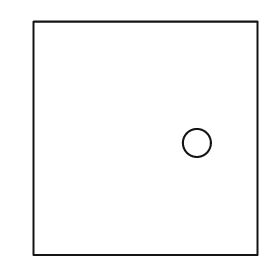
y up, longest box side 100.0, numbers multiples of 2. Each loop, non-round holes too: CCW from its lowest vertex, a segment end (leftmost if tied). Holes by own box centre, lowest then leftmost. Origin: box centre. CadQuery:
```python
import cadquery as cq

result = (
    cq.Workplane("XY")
    .moveTo(-48.0, -50.0)
    .lineTo(48.0, -50.0)
    .lineTo(48.0, 50.0)
    .lineTo(-48.0, 50.0)
    .close()
    .moveTo(22.0, -2.0)
    .circle(6.0)
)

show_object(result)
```